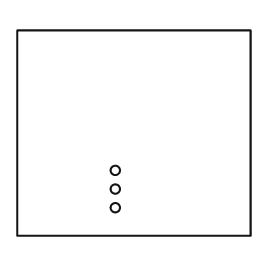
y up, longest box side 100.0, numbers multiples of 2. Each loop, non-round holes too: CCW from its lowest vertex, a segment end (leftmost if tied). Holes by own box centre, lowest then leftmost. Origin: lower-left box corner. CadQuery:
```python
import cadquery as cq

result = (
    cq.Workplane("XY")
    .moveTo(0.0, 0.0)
    .lineTo(100.0, 0.0)
    .lineTo(100.0, 88.0)
    .lineTo(0.0, 88.0)
    .close()
    .moveTo(42.0, 12.0)
    .circle(2.0)
    .moveTo(42.0, 20.0)
    .circle(2.0)
    .moveTo(42.0, 28.0)
    .circle(2.0)
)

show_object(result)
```